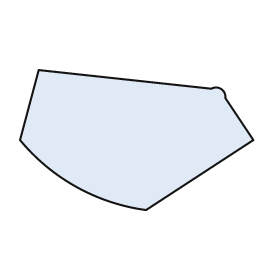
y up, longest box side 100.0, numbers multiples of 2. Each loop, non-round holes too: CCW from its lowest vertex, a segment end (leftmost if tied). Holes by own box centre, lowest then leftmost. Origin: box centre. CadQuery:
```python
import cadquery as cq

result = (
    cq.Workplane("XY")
    .moveTo(4.0, -30.0)
    .lineTo(50.0, 0.0)
    .lineTo(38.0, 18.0)
    .threePointArc((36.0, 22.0), (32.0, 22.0))
    .lineTo(-42.0, 30.0)
    .lineTo(-50.0, 0.0)
    .threePointArc((-26.0, -20.0), (4.0, -30.0))
    .close()
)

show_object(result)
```